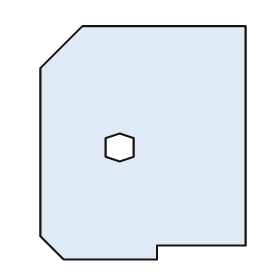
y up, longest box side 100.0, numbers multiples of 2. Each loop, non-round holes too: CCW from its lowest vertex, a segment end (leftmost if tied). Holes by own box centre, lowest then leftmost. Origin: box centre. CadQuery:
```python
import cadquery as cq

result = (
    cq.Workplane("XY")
    .moveTo(-34.0, -50.0)
    .lineTo(6.0, -50.0)
    .lineTo(6.0, -44.0)
    .lineTo(44.0, -44.0)
    .lineTo(44.0, 50.0)
    .lineTo(-26.0, 50.0)
    .lineTo(-44.0, 32.0)
    .lineTo(-44.0, -40.0)
    .close()
    .moveTo(-10.0, -8.0)
    .lineTo(-4.0, -6.0)
    .lineTo(-4.0, 2.0)
    .lineTo(-10.0, 4.0)
    .lineTo(-16.0, 2.0)
    .lineTo(-16.0, -6.0)
    .close()
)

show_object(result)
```